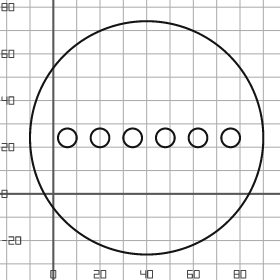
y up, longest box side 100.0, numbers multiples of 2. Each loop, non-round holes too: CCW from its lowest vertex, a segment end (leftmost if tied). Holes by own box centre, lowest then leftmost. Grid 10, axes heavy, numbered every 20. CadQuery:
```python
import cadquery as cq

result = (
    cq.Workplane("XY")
    .moveTo(40.0, 24.0)
    .circle(50.0)
    .moveTo(6.0, 24.0)
    .circle(4.0)
    .moveTo(20.0, 24.0)
    .circle(4.0)
    .moveTo(34.0, 24.0)
    .circle(4.0)
    .moveTo(48.0, 24.0)
    .circle(4.0)
    .moveTo(62.0, 24.0)
    .circle(4.0)
    .moveTo(76.0, 24.0)
    .circle(4.0)
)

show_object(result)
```